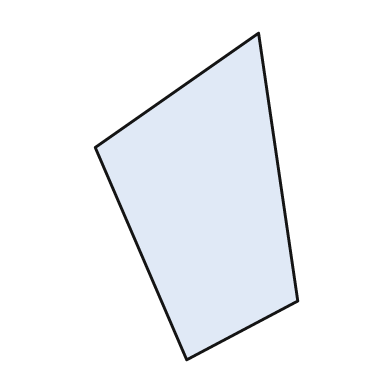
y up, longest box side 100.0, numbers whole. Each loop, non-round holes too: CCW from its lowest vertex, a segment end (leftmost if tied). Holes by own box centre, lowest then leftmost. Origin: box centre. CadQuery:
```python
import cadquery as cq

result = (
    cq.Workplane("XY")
    .moveTo(-3.0, -50.0)
    .lineTo(31.0, -32.0)
    .lineTo(19.0, 50.0)
    .lineTo(-31.0, 15.0)
    .close()
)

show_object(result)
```